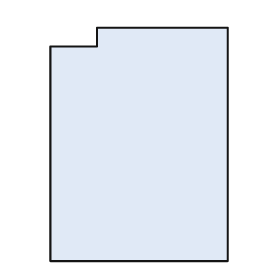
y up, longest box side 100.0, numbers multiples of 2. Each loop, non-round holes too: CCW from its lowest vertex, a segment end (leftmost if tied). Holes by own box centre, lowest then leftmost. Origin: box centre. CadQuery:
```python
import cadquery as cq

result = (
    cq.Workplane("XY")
    .moveTo(-38.0, -50.0)
    .lineTo(38.0, -50.0)
    .lineTo(38.0, 50.0)
    .lineTo(-18.0, 50.0)
    .lineTo(-18.0, 42.0)
    .lineTo(-38.0, 42.0)
    .close()
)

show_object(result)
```